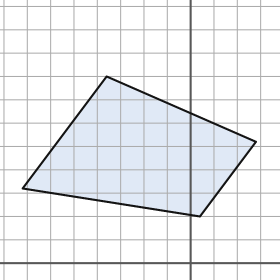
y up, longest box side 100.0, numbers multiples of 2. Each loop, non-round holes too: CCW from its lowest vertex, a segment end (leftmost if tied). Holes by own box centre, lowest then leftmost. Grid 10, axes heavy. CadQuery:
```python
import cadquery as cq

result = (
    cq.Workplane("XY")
    .moveTo(4.0, 20.0)
    .lineTo(28.0, 52.0)
    .lineTo(-36.0, 80.0)
    .lineTo(-72.0, 32.0)
    .close()
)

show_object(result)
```